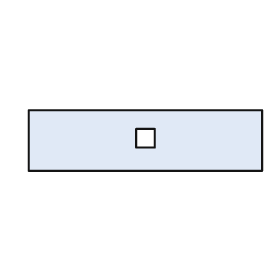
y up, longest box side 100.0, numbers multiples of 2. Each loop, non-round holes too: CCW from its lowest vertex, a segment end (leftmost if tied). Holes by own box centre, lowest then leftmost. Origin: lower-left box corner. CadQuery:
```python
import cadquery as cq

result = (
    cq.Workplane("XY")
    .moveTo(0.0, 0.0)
    .lineTo(100.0, 0.0)
    .lineTo(100.0, 26.0)
    .lineTo(0.0, 26.0)
    .close()
    .moveTo(46.0, 10.0)
    .lineTo(54.0, 10.0)
    .lineTo(54.0, 18.0)
    .lineTo(46.0, 18.0)
    .close()
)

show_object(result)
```